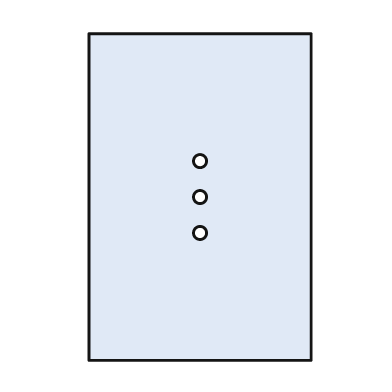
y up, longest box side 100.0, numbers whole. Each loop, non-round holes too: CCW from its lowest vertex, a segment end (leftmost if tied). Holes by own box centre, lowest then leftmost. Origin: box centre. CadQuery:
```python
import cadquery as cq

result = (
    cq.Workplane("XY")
    .moveTo(-34.0, -50.0)
    .lineTo(34.0, -50.0)
    .lineTo(34.0, 50.0)
    .lineTo(-34.0, 50.0)
    .close()
    .moveTo(0.0, -11.0)
    .circle(2.0)
    .moveTo(0.0, 0.0)
    .circle(2.0)
    .moveTo(0.0, 11.0)
    .circle(2.0)
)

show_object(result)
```